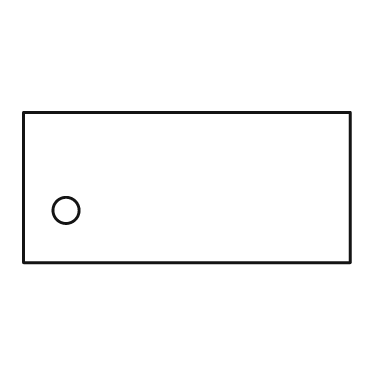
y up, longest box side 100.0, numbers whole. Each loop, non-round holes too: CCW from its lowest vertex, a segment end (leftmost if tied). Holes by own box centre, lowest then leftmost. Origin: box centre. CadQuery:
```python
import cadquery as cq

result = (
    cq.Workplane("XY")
    .moveTo(-50.0, -23.0)
    .lineTo(50.0, -23.0)
    .lineTo(50.0, 23.0)
    .lineTo(-50.0, 23.0)
    .close()
    .moveTo(-37.0, -7.0)
    .circle(4.0)
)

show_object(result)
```